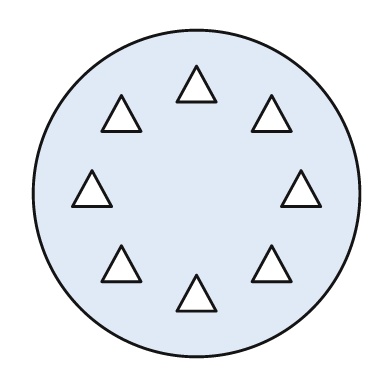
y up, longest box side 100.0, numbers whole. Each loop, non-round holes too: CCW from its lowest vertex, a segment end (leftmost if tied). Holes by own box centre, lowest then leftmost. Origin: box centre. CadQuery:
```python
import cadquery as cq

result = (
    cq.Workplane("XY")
    .moveTo(0.0, 0.0)
    .circle(50.0)
    .moveTo(-6.0, -36.0)
    .lineTo(6.0, -36.0)
    .lineTo(0.0, -25.0)
    .close()
    .moveTo(-29.0, -27.0)
    .lineTo(-17.0, -27.0)
    .lineTo(-23.0, -16.0)
    .close()
    .moveTo(17.0, -27.0)
    .lineTo(29.0, -27.0)
    .lineTo(23.0, -16.0)
    .close()
    .moveTo(-38.0, -4.0)
    .lineTo(-26.0, -4.0)
    .lineTo(-32.0, 7.0)
    .close()
    .moveTo(26.0, -4.0)
    .lineTo(38.0, -4.0)
    .lineTo(32.0, 7.0)
    .close()
    .moveTo(-29.0, 19.0)
    .lineTo(-17.0, 19.0)
    .lineTo(-23.0, 30.0)
    .close()
    .moveTo(17.0, 19.0)
    .lineTo(29.0, 19.0)
    .lineTo(23.0, 30.0)
    .close()
    .moveTo(-6.0, 28.0)
    .lineTo(6.0, 28.0)
    .lineTo(0.0, 39.0)
    .close()
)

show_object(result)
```